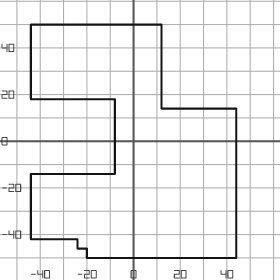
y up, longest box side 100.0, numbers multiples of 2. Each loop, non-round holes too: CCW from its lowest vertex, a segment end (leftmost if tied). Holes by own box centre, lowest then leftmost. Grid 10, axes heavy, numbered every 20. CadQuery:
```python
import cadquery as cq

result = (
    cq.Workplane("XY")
    .moveTo(-20.0, -50.0)
    .lineTo(44.0, -50.0)
    .lineTo(44.0, 14.0)
    .lineTo(12.0, 14.0)
    .lineTo(12.0, 50.0)
    .lineTo(-44.0, 50.0)
    .lineTo(-44.0, 18.0)
    .lineTo(-8.0, 18.0)
    .lineTo(-8.0, -14.0)
    .lineTo(-44.0, -14.0)
    .lineTo(-44.0, -42.0)
    .lineTo(-24.0, -42.0)
    .lineTo(-24.0, -46.0)
    .lineTo(-20.0, -46.0)
    .close()
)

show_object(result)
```